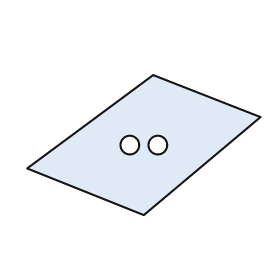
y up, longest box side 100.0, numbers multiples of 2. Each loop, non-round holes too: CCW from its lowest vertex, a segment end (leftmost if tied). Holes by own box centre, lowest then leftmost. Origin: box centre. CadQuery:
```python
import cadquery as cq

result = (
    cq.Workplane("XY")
    .moveTo(0.0, -30.0)
    .lineTo(50.0, 12.0)
    .lineTo(4.0, 30.0)
    .lineTo(-50.0, -10.0)
    .close()
    .moveTo(-6.0, 0.0)
    .circle(4.0)
    .moveTo(6.0, 0.0)
    .circle(4.0)
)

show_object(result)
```